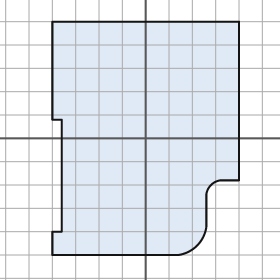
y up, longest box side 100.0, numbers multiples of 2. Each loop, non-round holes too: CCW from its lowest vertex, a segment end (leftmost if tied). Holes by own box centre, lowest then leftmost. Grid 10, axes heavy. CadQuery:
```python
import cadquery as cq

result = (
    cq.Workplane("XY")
    .moveTo(-40.0, -50.0)
    .lineTo(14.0, -50.0)
    .threePointArc((22.0, -46.0), (26.0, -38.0))
    .lineTo(26.0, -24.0)
    .threePointArc((28.0, -20.0), (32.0, -18.0))
    .lineTo(40.0, -18.0)
    .lineTo(40.0, 50.0)
    .lineTo(-40.0, 50.0)
    .lineTo(-40.0, 8.0)
    .lineTo(-36.0, 8.0)
    .lineTo(-36.0, -40.0)
    .lineTo(-40.0, -40.0)
    .close()
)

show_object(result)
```